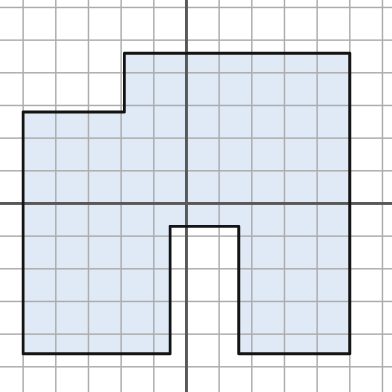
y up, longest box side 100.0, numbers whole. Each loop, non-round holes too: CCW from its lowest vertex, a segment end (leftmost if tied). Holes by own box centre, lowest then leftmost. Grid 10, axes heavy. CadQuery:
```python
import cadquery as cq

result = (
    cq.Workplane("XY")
    .moveTo(-50.0, -46.0)
    .lineTo(-5.0, -46.0)
    .lineTo(-5.0, -7.0)
    .lineTo(16.0, -7.0)
    .lineTo(16.0, -46.0)
    .lineTo(50.0, -46.0)
    .lineTo(50.0, 46.0)
    .lineTo(-19.0, 46.0)
    .lineTo(-19.0, 28.0)
    .lineTo(-50.0, 28.0)
    .close()
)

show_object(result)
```